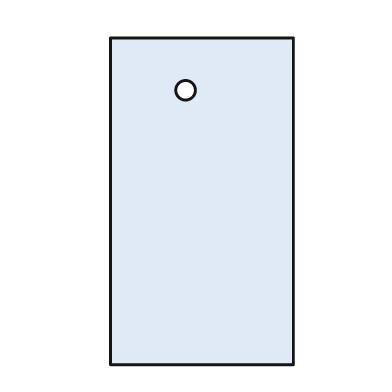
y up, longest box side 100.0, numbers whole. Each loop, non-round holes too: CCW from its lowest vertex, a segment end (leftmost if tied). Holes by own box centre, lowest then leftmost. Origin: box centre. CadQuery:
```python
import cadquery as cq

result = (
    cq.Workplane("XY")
    .moveTo(-28.0, -50.0)
    .lineTo(28.0, -50.0)
    .lineTo(28.0, 50.0)
    .lineTo(-28.0, 50.0)
    .close()
    .moveTo(-5.0, 34.0)
    .circle(3.0)
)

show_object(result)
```